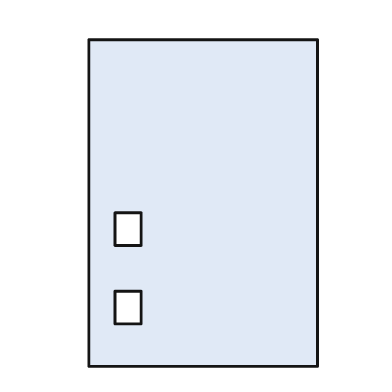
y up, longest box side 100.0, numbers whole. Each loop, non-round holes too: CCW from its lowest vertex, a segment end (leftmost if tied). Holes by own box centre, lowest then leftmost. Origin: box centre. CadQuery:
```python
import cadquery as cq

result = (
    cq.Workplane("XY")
    .moveTo(-35.0, -50.0)
    .lineTo(35.0, -50.0)
    .lineTo(35.0, 50.0)
    .lineTo(-35.0, 50.0)
    .close()
    .moveTo(-27.0, -37.0)
    .lineTo(-19.0, -37.0)
    .lineTo(-19.0, -27.0)
    .lineTo(-27.0, -27.0)
    .close()
    .moveTo(-27.0, -13.0)
    .lineTo(-19.0, -13.0)
    .lineTo(-19.0, -3.0)
    .lineTo(-27.0, -3.0)
    .close()
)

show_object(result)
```